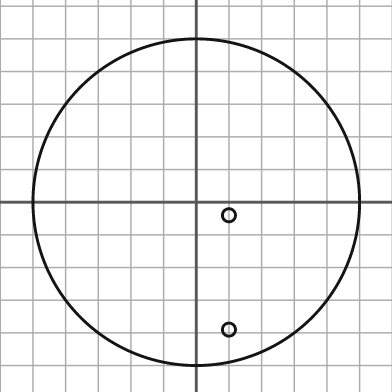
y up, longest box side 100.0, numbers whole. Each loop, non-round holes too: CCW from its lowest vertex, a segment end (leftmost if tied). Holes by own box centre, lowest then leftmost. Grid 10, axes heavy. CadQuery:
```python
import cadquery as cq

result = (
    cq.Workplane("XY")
    .moveTo(0.0, 0.0)
    .circle(50.0)
    .moveTo(10.0, -39.0)
    .circle(2.0)
    .moveTo(10.0, -4.0)
    .circle(2.0)
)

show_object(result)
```